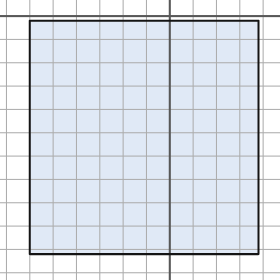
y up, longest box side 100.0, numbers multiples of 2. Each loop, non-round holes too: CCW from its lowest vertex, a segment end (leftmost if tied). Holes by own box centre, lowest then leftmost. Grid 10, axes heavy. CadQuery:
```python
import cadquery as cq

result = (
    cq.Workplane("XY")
    .moveTo(-60.0, -102.0)
    .lineTo(38.0, -102.0)
    .lineTo(38.0, -2.0)
    .lineTo(-60.0, -2.0)
    .close()
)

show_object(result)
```